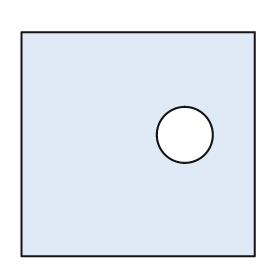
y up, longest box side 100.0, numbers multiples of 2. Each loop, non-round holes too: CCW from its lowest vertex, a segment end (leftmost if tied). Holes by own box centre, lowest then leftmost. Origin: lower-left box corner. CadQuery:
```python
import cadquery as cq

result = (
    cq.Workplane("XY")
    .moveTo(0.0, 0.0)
    .lineTo(100.0, 0.0)
    .lineTo(100.0, 96.0)
    .lineTo(0.0, 96.0)
    .close()
    .moveTo(70.0, 52.0)
    .circle(12.0)
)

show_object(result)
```